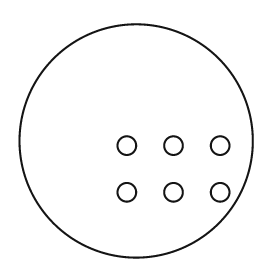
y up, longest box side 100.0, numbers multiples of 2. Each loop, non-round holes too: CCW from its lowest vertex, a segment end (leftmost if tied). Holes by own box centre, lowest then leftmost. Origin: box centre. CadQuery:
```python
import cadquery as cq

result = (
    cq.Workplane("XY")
    .moveTo(0.0, 0.0)
    .circle(50.0)
    .moveTo(-4.0, -22.0)
    .circle(4.0)
    .moveTo(16.0, -22.0)
    .circle(4.0)
    .moveTo(36.0, -22.0)
    .circle(4.0)
    .moveTo(-4.0, -2.0)
    .circle(4.0)
    .moveTo(16.0, -2.0)
    .circle(4.0)
    .moveTo(36.0, -2.0)
    .circle(4.0)
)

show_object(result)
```